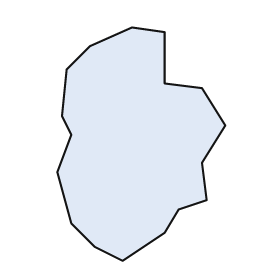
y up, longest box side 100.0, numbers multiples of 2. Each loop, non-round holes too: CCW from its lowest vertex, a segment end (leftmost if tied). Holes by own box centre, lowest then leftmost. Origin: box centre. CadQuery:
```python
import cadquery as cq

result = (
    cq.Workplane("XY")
    .moveTo(-8.0, -50.0)
    .lineTo(10.0, -38.0)
    .lineTo(16.0, -28.0)
    .lineTo(28.0, -24.0)
    .lineTo(26.0, -8.0)
    .lineTo(36.0, 8.0)
    .lineTo(26.0, 24.0)
    .lineTo(10.0, 26.0)
    .lineTo(10.0, 48.0)
    .lineTo(-4.0, 50.0)
    .lineTo(-22.0, 42.0)
    .lineTo(-32.0, 32.0)
    .lineTo(-34.0, 12.0)
    .lineTo(-30.0, 4.0)
    .lineTo(-36.0, -12.0)
    .lineTo(-30.0, -34.0)
    .lineTo(-20.0, -44.0)
    .close()
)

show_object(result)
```